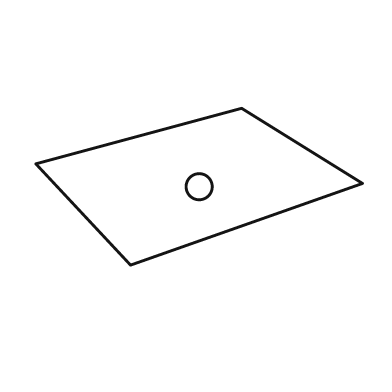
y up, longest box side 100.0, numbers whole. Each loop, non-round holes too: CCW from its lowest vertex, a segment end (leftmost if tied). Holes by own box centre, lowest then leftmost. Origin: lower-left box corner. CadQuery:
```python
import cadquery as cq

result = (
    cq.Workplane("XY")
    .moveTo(29.0, 0.0)
    .lineTo(100.0, 25.0)
    .lineTo(63.0, 48.0)
    .lineTo(0.0, 31.0)
    .close()
    .moveTo(50.0, 24.0)
    .circle(4.0)
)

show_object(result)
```